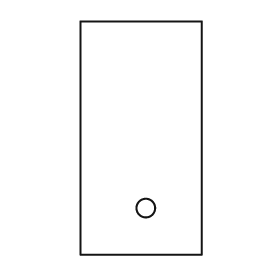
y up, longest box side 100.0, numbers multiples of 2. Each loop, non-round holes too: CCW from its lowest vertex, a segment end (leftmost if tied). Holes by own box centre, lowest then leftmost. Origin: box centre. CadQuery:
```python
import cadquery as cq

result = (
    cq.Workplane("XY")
    .moveTo(-26.0, -50.0)
    .lineTo(26.0, -50.0)
    .lineTo(26.0, 50.0)
    .lineTo(-26.0, 50.0)
    .close()
    .moveTo(2.0, -30.0)
    .circle(4.0)
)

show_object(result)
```